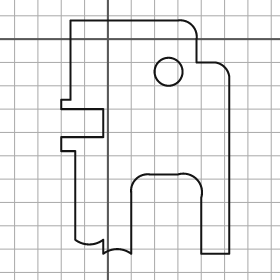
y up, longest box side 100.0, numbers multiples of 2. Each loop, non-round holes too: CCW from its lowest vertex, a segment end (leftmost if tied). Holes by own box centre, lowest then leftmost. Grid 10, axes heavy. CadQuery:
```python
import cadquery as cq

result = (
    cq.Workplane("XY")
    .moveTo(-2.0, -92.0)
    .threePointArc((4.0, -90.0), (10.0, -92.0))
    .lineTo(10.0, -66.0)
    .threePointArc((12.0, -60.0), (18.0, -58.0))
    .lineTo(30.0, -58.0)
    .threePointArc((38.0, -60.0), (40.0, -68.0))
    .lineTo(40.0, -92.0)
    .lineTo(52.0, -92.0)
    .lineTo(52.0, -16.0)
    .threePointArc((50.0, -12.0), (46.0, -10.0))
    .lineTo(38.0, -10.0)
    .lineTo(38.0, 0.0)
    .threePointArc((36.0, 6.0), (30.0, 8.0))
    .lineTo(-16.0, 8.0)
    .lineTo(-16.0, -26.0)
    .lineTo(-20.0, -26.0)
    .lineTo(-20.0, -30.0)
    .lineTo(-2.0, -30.0)
    .lineTo(-2.0, -42.0)
    .lineTo(-20.0, -42.0)
    .lineTo(-20.0, -48.0)
    .lineTo(-14.0, -48.0)
    .lineTo(-14.0, -86.0)
    .threePointArc((-8.0, -88.0), (-2.0, -86.0))
    .close()
    .moveTo(26.0, -14.0)
    .circle(6.0)
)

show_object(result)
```